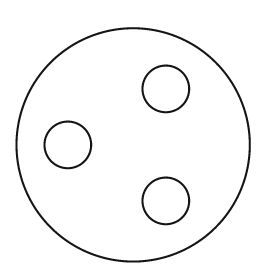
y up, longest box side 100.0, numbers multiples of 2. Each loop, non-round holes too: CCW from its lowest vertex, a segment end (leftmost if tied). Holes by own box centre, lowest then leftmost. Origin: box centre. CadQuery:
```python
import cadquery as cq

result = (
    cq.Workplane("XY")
    .moveTo(0.0, 0.0)
    .circle(50.0)
    .moveTo(14.0, -24.0)
    .circle(10.0)
    .moveTo(-28.0, 0.0)
    .circle(10.0)
    .moveTo(14.0, 24.0)
    .circle(10.0)
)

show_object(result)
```